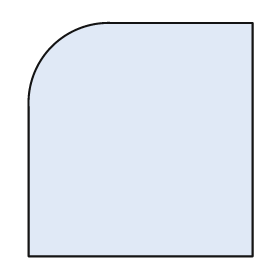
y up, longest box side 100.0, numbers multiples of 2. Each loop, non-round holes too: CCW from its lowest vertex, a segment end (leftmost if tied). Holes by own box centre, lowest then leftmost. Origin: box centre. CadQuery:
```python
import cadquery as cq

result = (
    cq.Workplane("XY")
    .moveTo(-48.0, -50.0)
    .lineTo(48.0, -50.0)
    .lineTo(48.0, 50.0)
    .lineTo(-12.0, 50.0)
    .threePointArc((-38.0, 40.0), (-48.0, 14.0))
    .close()
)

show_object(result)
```